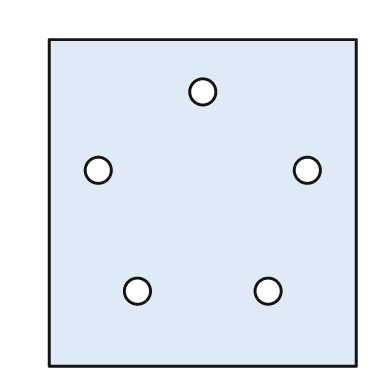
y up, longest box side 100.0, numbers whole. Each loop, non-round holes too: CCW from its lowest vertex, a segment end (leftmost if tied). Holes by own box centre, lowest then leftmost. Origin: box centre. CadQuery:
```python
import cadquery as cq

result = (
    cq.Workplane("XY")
    .moveTo(-47.0, -50.0)
    .lineTo(47.0, -50.0)
    .lineTo(47.0, 50.0)
    .lineTo(-47.0, 50.0)
    .close()
    .moveTo(-20.0, -27.0)
    .circle(4.0)
    .moveTo(20.0, -27.0)
    .circle(4.0)
    .moveTo(-32.0, 10.0)
    .circle(4.0)
    .moveTo(32.0, 10.0)
    .circle(4.0)
    .moveTo(0.0, 34.0)
    .circle(4.0)
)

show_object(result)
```